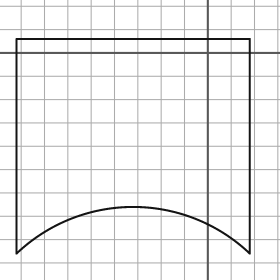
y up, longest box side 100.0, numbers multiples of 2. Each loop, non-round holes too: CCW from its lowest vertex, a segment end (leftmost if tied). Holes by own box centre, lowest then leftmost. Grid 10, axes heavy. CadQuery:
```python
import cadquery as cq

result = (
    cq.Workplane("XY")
    .moveTo(-82.0, -86.0)
    .threePointArc((-32.0, -66.0), (18.0, -86.0))
    .lineTo(18.0, 6.0)
    .lineTo(-82.0, 6.0)
    .close()
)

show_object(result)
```